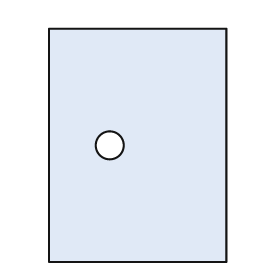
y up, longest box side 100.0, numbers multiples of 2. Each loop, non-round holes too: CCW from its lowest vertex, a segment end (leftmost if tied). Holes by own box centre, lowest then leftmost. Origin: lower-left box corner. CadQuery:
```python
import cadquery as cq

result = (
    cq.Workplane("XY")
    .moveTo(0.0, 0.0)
    .lineTo(76.0, 0.0)
    .lineTo(76.0, 100.0)
    .lineTo(0.0, 100.0)
    .close()
    .moveTo(26.0, 50.0)
    .circle(6.0)
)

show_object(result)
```